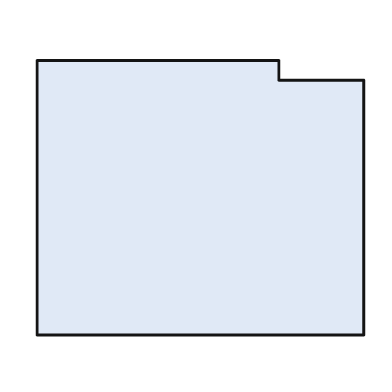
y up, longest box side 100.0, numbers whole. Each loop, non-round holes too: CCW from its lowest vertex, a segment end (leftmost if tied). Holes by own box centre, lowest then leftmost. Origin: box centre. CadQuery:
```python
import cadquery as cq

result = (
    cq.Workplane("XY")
    .moveTo(-50.0, -42.0)
    .lineTo(50.0, -42.0)
    .lineTo(50.0, 36.0)
    .lineTo(24.0, 36.0)
    .lineTo(24.0, 42.0)
    .lineTo(-50.0, 42.0)
    .close()
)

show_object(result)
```